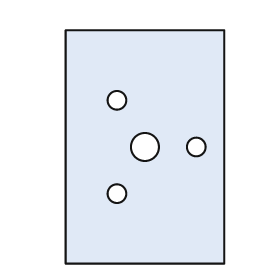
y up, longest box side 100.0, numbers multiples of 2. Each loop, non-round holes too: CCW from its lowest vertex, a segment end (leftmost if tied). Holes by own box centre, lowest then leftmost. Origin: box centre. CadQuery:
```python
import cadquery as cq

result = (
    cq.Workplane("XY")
    .moveTo(-34.0, -50.0)
    .lineTo(34.0, -50.0)
    .lineTo(34.0, 50.0)
    .lineTo(-34.0, 50.0)
    .close()
    .moveTo(-12.0, -20.0)
    .circle(4.0)
    .moveTo(0.0, 0.0)
    .circle(6.0)
    .moveTo(22.0, 0.0)
    .circle(4.0)
    .moveTo(-12.0, 20.0)
    .circle(4.0)
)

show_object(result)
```